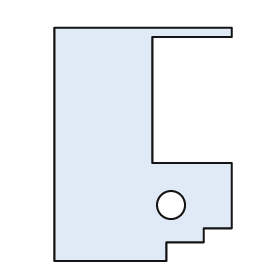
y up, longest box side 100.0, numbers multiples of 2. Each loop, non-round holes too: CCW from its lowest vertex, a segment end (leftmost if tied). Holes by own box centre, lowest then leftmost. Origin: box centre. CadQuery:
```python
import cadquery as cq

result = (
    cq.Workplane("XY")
    .moveTo(-38.0, -50.0)
    .lineTo(10.0, -50.0)
    .lineTo(10.0, -42.0)
    .lineTo(26.0, -42.0)
    .lineTo(26.0, -36.0)
    .lineTo(38.0, -36.0)
    .lineTo(38.0, -8.0)
    .lineTo(4.0, -8.0)
    .lineTo(4.0, 46.0)
    .lineTo(38.0, 46.0)
    .lineTo(38.0, 50.0)
    .lineTo(-38.0, 50.0)
    .close()
    .moveTo(12.0, -26.0)
    .circle(6.0)
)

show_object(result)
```